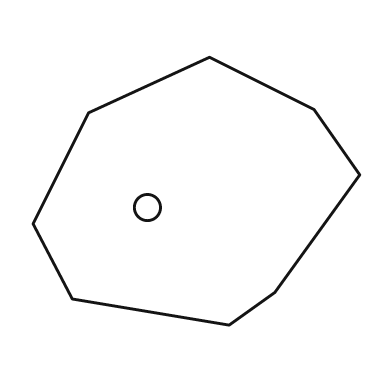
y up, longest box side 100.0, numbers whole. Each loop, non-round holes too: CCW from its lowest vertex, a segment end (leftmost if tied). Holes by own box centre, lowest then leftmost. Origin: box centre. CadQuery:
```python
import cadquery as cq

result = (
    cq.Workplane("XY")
    .moveTo(10.0, -41.0)
    .lineTo(24.0, -31.0)
    .lineTo(50.0, 5.0)
    .lineTo(36.0, 25.0)
    .lineTo(4.0, 41.0)
    .lineTo(-33.0, 24.0)
    .lineTo(-50.0, -10.0)
    .lineTo(-38.0, -33.0)
    .close()
    .moveTo(-15.0, -5.0)
    .circle(4.0)
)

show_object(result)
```